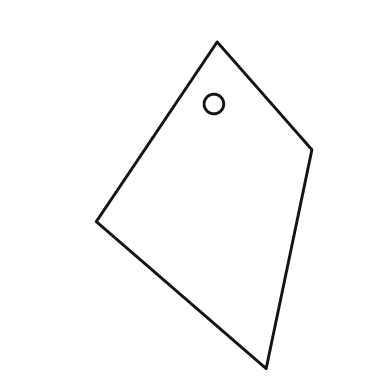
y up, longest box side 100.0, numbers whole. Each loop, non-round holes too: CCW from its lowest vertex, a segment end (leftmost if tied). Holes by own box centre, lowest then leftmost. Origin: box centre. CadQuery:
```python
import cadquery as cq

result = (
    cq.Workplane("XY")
    .moveTo(19.0, -50.0)
    .lineTo(33.0, 17.0)
    .lineTo(4.0, 50.0)
    .lineTo(-33.0, -5.0)
    .close()
    .moveTo(3.0, 31.0)
    .circle(3.0)
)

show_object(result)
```